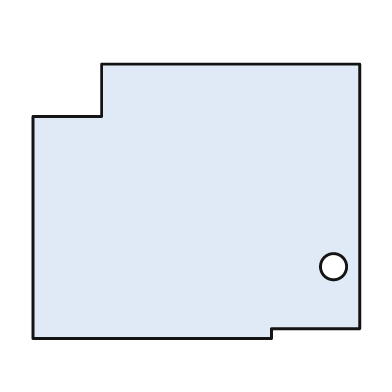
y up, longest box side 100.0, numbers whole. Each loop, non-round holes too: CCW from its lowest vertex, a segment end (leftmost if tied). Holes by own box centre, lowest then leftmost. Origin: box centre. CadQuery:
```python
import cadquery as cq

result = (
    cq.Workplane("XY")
    .moveTo(-50.0, -42.0)
    .lineTo(23.0, -42.0)
    .lineTo(23.0, -39.0)
    .lineTo(50.0, -39.0)
    .lineTo(50.0, 42.0)
    .lineTo(-29.0, 42.0)
    .lineTo(-29.0, 26.0)
    .lineTo(-50.0, 26.0)
    .close()
    .moveTo(42.0, -20.0)
    .circle(4.0)
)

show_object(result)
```